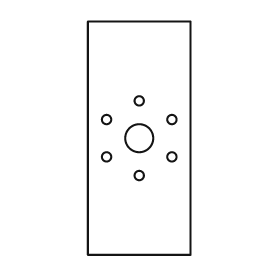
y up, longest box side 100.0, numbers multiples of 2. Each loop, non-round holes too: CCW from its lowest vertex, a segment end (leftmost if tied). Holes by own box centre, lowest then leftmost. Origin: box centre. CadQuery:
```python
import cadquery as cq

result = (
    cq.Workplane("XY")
    .moveTo(-22.0, -50.0)
    .lineTo(22.0, -50.0)
    .lineTo(22.0, 50.0)
    .lineTo(-22.0, 50.0)
    .close()
    .moveTo(0.0, -16.0)
    .circle(2.0)
    .moveTo(-14.0, -8.0)
    .circle(2.0)
    .moveTo(14.0, -8.0)
    .circle(2.0)
    .moveTo(0.0, 0.0)
    .circle(6.0)
    .moveTo(-14.0, 8.0)
    .circle(2.0)
    .moveTo(14.0, 8.0)
    .circle(2.0)
    .moveTo(0.0, 16.0)
    .circle(2.0)
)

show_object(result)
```